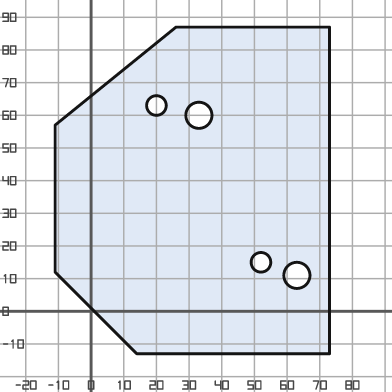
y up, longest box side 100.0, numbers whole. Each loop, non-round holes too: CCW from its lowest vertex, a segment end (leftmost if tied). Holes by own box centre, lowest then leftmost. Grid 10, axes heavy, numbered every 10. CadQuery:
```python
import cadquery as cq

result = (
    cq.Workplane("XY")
    .moveTo(14.0, -13.0)
    .lineTo(73.0, -13.0)
    .lineTo(73.0, 87.0)
    .lineTo(26.0, 87.0)
    .lineTo(-11.0, 57.0)
    .lineTo(-11.0, 12.0)
    .close()
    .moveTo(63.0, 11.0)
    .circle(4.0)
    .moveTo(52.0, 15.0)
    .circle(3.0)
    .moveTo(33.0, 60.0)
    .circle(4.0)
    .moveTo(20.0, 63.0)
    .circle(3.0)
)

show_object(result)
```